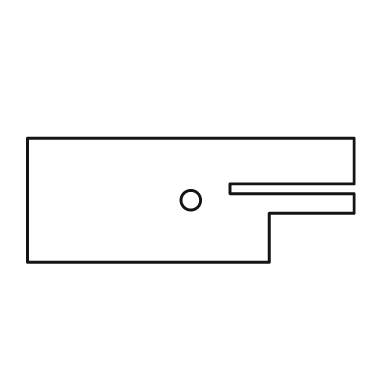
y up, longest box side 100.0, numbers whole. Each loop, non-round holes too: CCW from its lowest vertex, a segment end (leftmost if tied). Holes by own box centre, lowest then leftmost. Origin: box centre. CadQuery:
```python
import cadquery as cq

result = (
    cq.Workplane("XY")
    .moveTo(-50.0, -19.0)
    .lineTo(24.0, -19.0)
    .lineTo(24.0, -4.0)
    .lineTo(50.0, -4.0)
    .lineTo(50.0, 2.0)
    .lineTo(12.0, 2.0)
    .lineTo(12.0, 5.0)
    .lineTo(50.0, 5.0)
    .lineTo(50.0, 19.0)
    .lineTo(-50.0, 19.0)
    .close()
    .moveTo(0.0, 0.0)
    .circle(3.0)
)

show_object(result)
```